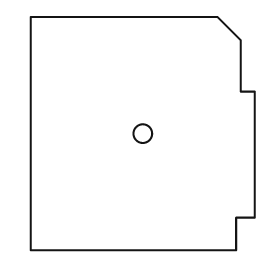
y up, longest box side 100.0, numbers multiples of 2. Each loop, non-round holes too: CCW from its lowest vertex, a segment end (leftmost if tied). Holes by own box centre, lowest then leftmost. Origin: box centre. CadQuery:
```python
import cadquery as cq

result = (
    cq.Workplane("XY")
    .moveTo(-48.0, -50.0)
    .lineTo(40.0, -50.0)
    .lineTo(40.0, -36.0)
    .lineTo(48.0, -36.0)
    .lineTo(48.0, 18.0)
    .lineTo(42.0, 18.0)
    .lineTo(42.0, 40.0)
    .lineTo(32.0, 50.0)
    .lineTo(-48.0, 50.0)
    .close()
    .moveTo(0.0, 0.0)
    .circle(4.0)
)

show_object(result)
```